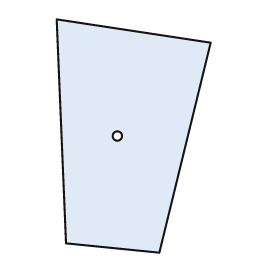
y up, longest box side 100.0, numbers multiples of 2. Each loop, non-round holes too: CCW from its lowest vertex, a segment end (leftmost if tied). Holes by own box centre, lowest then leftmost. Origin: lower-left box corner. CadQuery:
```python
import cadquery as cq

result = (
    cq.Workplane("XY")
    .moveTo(44.0, 0.0)
    .lineTo(66.0, 90.0)
    .lineTo(0.0, 100.0)
    .lineTo(4.0, 4.0)
    .close()
    .moveTo(26.0, 50.0)
    .circle(2.0)
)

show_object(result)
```